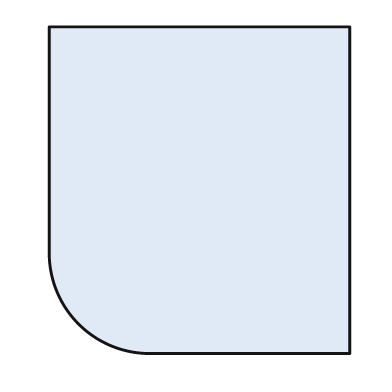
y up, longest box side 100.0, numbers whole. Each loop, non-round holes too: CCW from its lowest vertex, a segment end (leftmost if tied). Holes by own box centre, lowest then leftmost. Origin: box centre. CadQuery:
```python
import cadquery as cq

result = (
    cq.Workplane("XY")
    .moveTo(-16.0, -50.0)
    .lineTo(46.0, -50.0)
    .lineTo(46.0, 50.0)
    .lineTo(-46.0, 50.0)
    .lineTo(-46.0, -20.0)
    .threePointArc((-37.0, -41.0), (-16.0, -50.0))
    .close()
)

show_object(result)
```